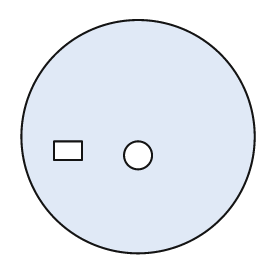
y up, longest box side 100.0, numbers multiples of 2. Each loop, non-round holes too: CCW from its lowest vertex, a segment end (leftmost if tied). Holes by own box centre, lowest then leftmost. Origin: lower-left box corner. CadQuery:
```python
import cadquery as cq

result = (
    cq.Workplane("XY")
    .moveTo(50.0, 50.0)
    .circle(50.0)
    .moveTo(50.0, 42.0)
    .circle(6.0)
    .moveTo(14.0, 40.0)
    .lineTo(26.0, 40.0)
    .lineTo(26.0, 48.0)
    .lineTo(14.0, 48.0)
    .close()
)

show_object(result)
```